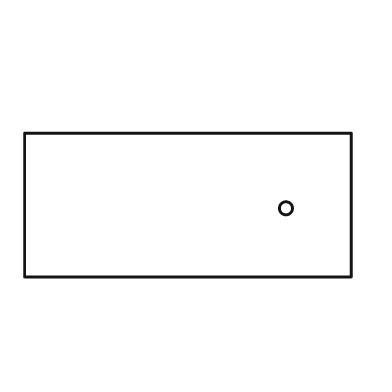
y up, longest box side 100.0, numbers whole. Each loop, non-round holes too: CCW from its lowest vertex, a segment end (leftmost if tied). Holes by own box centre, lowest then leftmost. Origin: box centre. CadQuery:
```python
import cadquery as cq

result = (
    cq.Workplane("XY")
    .moveTo(-50.0, -22.0)
    .lineTo(50.0, -22.0)
    .lineTo(50.0, 22.0)
    .lineTo(-50.0, 22.0)
    .close()
    .moveTo(30.0, -1.0)
    .circle(2.0)
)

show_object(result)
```